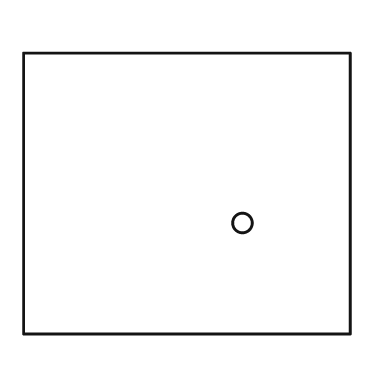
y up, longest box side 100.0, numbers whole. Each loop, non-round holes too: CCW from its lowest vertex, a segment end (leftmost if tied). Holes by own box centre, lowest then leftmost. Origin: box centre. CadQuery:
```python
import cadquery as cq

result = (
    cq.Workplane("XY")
    .moveTo(-50.0, -43.0)
    .lineTo(50.0, -43.0)
    .lineTo(50.0, 43.0)
    .lineTo(-50.0, 43.0)
    .close()
    .moveTo(17.0, -9.0)
    .circle(3.0)
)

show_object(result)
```